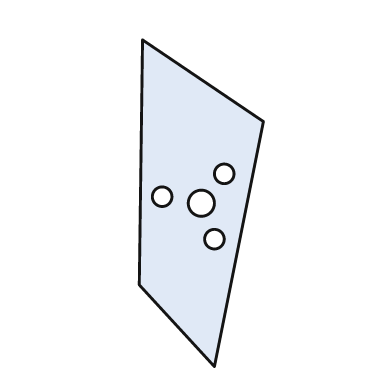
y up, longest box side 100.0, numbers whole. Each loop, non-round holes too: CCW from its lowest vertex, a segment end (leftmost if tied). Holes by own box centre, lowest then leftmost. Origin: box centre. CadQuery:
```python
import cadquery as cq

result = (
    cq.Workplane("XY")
    .moveTo(4.0, -50.0)
    .lineTo(19.0, 25.0)
    .lineTo(-18.0, 50.0)
    .lineTo(-19.0, -25.0)
    .close()
    .moveTo(4.0, -11.0)
    .circle(3.0)
    .moveTo(0.0, 0.0)
    .circle(4.0)
    .moveTo(-12.0, 2.0)
    .circle(3.0)
    .moveTo(7.0, 9.0)
    .circle(3.0)
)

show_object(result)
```